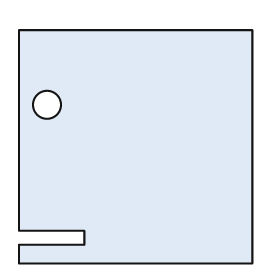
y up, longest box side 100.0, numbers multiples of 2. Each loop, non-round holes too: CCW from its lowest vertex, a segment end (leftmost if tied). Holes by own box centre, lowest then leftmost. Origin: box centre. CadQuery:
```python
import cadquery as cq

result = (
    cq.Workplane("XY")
    .moveTo(-50.0, -50.0)
    .lineTo(50.0, -50.0)
    .lineTo(50.0, 50.0)
    .lineTo(-50.0, 50.0)
    .lineTo(-50.0, -36.0)
    .lineTo(-22.0, -36.0)
    .lineTo(-22.0, -42.0)
    .lineTo(-50.0, -42.0)
    .close()
    .moveTo(-38.0, 18.0)
    .circle(6.0)
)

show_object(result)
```